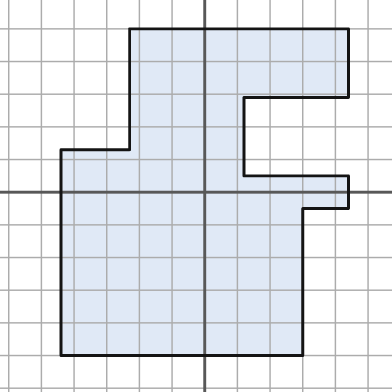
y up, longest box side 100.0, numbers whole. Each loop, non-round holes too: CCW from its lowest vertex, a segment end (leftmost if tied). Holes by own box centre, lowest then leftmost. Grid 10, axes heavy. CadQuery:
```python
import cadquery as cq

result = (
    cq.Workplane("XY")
    .moveTo(-44.0, -50.0)
    .lineTo(30.0, -50.0)
    .lineTo(30.0, -5.0)
    .lineTo(44.0, -5.0)
    .lineTo(44.0, 5.0)
    .lineTo(12.0, 5.0)
    .lineTo(12.0, 29.0)
    .lineTo(44.0, 29.0)
    .lineTo(44.0, 50.0)
    .lineTo(-23.0, 50.0)
    .lineTo(-23.0, 13.0)
    .lineTo(-44.0, 13.0)
    .close()
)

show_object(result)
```